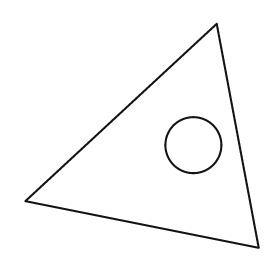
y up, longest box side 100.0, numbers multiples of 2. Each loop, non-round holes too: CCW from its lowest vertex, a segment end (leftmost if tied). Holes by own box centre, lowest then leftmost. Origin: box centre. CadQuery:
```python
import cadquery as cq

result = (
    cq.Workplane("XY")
    .moveTo(50.0, -48.0)
    .lineTo(32.0, 48.0)
    .lineTo(-50.0, -28.0)
    .close()
    .moveTo(22.0, -4.0)
    .circle(12.0)
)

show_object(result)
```